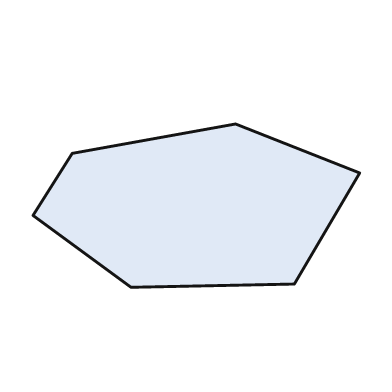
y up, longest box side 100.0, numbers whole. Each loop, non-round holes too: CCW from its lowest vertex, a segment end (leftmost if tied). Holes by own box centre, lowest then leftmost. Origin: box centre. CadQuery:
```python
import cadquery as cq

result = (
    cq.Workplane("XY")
    .moveTo(-20.0, -25.0)
    .lineTo(30.0, -24.0)
    .lineTo(50.0, 10.0)
    .lineTo(12.0, 25.0)
    .lineTo(-38.0, 16.0)
    .lineTo(-50.0, -3.0)
    .close()
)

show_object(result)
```